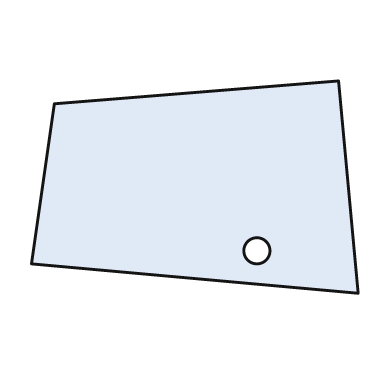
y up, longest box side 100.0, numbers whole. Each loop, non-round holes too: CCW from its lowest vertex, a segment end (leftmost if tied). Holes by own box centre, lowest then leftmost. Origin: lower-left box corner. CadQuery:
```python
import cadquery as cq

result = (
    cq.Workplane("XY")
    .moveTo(100.0, 0.0)
    .lineTo(94.0, 65.0)
    .lineTo(7.0, 58.0)
    .lineTo(0.0, 9.0)
    .close()
    .moveTo(69.0, 13.0)
    .circle(4.0)
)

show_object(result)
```